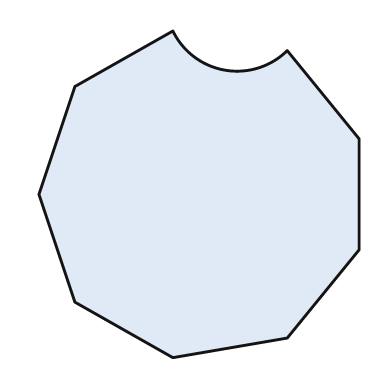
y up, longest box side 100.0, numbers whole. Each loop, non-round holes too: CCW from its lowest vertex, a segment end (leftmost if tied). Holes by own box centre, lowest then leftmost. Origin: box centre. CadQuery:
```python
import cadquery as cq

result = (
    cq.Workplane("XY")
    .moveTo(-8.0, -50.0)
    .lineTo(27.0, -44.0)
    .lineTo(49.0, -17.0)
    .lineTo(49.0, 17.0)
    .lineTo(27.0, 44.0)
    .threePointArc((8.0, 38.0), (-8.0, 50.0))
    .lineTo(-38.0, 33.0)
    .lineTo(-49.0, 0.0)
    .lineTo(-38.0, -33.0)
    .close()
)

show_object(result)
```